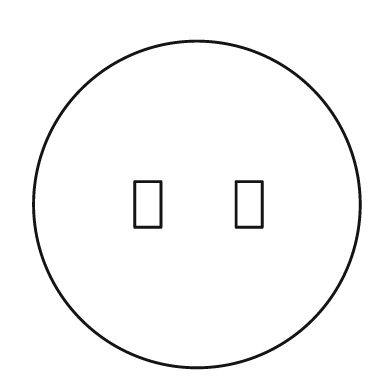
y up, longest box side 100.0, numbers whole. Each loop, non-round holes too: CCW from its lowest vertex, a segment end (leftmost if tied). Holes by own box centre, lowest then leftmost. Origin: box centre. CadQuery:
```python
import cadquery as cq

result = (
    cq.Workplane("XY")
    .moveTo(0.0, 0.0)
    .circle(50.0)
    .moveTo(-19.0, -7.0)
    .lineTo(-11.0, -7.0)
    .lineTo(-11.0, 7.0)
    .lineTo(-19.0, 7.0)
    .close()
    .moveTo(12.0, -7.0)
    .lineTo(20.0, -7.0)
    .lineTo(20.0, 7.0)
    .lineTo(12.0, 7.0)
    .close()
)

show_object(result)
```